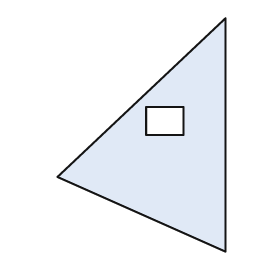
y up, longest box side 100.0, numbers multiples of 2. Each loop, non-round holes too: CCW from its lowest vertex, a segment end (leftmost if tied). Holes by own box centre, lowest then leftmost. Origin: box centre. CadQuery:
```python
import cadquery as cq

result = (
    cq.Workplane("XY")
    .moveTo(36.0, -50.0)
    .lineTo(36.0, 50.0)
    .lineTo(-36.0, -18.0)
    .close()
    .moveTo(2.0, 0.0)
    .lineTo(18.0, 0.0)
    .lineTo(18.0, 12.0)
    .lineTo(2.0, 12.0)
    .close()
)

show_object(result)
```